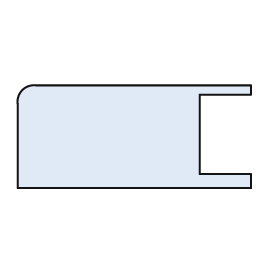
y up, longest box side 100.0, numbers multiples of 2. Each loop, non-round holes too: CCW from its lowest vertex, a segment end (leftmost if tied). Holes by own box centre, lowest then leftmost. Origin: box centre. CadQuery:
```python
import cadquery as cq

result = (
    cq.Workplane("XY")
    .moveTo(-50.0, -22.0)
    .lineTo(50.0, -22.0)
    .lineTo(50.0, -16.0)
    .lineTo(28.0, -16.0)
    .lineTo(28.0, 18.0)
    .lineTo(50.0, 18.0)
    .lineTo(50.0, 22.0)
    .lineTo(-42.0, 22.0)
    .threePointArc((-48.0, 20.0), (-50.0, 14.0))
    .close()
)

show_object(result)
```